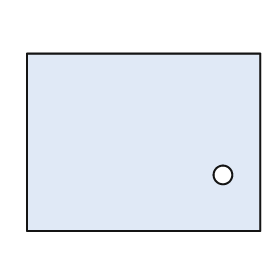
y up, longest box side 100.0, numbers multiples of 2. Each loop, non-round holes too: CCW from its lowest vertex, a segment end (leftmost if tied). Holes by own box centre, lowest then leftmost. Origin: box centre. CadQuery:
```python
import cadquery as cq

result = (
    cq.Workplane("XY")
    .moveTo(-50.0, -38.0)
    .lineTo(50.0, -38.0)
    .lineTo(50.0, 38.0)
    .lineTo(-50.0, 38.0)
    .close()
    .moveTo(34.0, -14.0)
    .circle(4.0)
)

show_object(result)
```